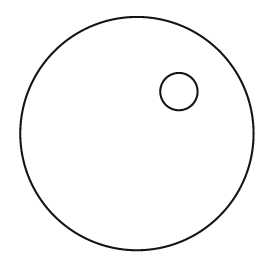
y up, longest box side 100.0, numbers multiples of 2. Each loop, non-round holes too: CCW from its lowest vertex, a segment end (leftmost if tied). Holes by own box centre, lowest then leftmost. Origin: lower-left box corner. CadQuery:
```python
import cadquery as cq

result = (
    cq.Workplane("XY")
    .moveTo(50.0, 50.0)
    .circle(50.0)
    .moveTo(68.0, 68.0)
    .circle(8.0)
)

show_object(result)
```